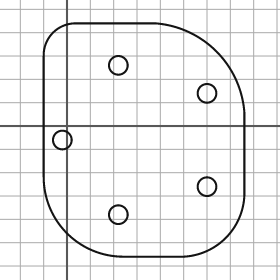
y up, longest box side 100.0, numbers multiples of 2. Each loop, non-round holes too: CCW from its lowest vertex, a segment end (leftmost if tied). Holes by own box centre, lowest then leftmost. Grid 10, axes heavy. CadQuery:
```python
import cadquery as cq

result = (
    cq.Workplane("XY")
    .moveTo(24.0, -56.0)
    .lineTo(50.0, -56.0)
    .threePointArc((68.0, -48.0), (76.0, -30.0))
    .lineTo(76.0, 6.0)
    .threePointArc((64.0, 32.0), (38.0, 44.0))
    .lineTo(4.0, 44.0)
    .threePointArc((-6.0, 40.0), (-10.0, 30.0))
    .lineTo(-10.0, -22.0)
    .threePointArc((0.0, -46.0), (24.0, -56.0))
    .close()
    .moveTo(22.0, -38.0)
    .circle(4.0)
    .moveTo(60.0, -26.0)
    .circle(4.0)
    .moveTo(-2.0, -6.0)
    .circle(4.0)
    .moveTo(60.0, 14.0)
    .circle(4.0)
    .moveTo(22.0, 26.0)
    .circle(4.0)
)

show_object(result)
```